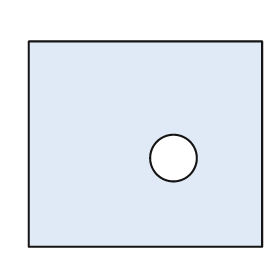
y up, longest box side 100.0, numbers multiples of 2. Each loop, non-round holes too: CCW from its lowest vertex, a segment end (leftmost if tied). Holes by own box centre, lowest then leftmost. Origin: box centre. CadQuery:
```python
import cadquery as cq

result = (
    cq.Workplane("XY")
    .moveTo(-50.0, -44.0)
    .lineTo(50.0, -44.0)
    .lineTo(50.0, 44.0)
    .lineTo(-50.0, 44.0)
    .close()
    .moveTo(12.0, -6.0)
    .circle(10.0)
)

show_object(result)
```